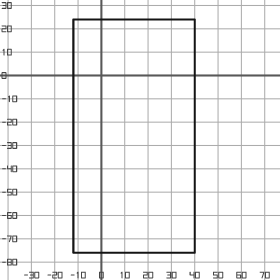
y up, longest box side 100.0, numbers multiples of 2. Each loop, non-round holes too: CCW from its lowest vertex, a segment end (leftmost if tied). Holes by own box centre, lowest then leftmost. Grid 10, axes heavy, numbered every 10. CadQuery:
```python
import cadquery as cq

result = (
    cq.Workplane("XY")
    .moveTo(-12.0, -76.0)
    .lineTo(40.0, -76.0)
    .lineTo(40.0, 24.0)
    .lineTo(-12.0, 24.0)
    .close()
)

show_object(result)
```